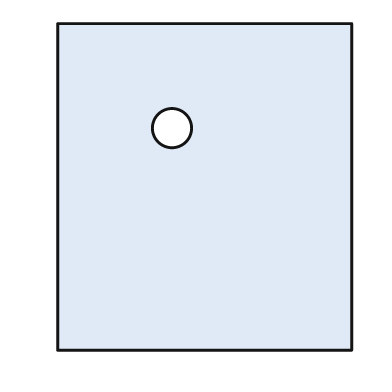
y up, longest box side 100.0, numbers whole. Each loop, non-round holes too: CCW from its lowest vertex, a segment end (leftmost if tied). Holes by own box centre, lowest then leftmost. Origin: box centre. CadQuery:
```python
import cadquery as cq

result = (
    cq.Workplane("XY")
    .moveTo(-45.0, -50.0)
    .lineTo(45.0, -50.0)
    .lineTo(45.0, 50.0)
    .lineTo(-45.0, 50.0)
    .close()
    .moveTo(-10.0, 18.0)
    .circle(6.0)
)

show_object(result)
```